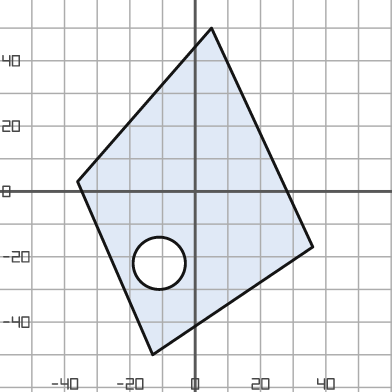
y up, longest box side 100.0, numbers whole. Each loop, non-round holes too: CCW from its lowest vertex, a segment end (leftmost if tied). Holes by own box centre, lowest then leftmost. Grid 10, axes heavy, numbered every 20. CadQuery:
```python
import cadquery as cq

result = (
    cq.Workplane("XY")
    .moveTo(-13.0, -50.0)
    .lineTo(36.0, -17.0)
    .lineTo(5.0, 50.0)
    .lineTo(-36.0, 3.0)
    .close()
    .moveTo(-11.0, -22.0)
    .circle(8.0)
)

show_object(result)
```